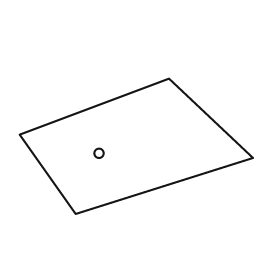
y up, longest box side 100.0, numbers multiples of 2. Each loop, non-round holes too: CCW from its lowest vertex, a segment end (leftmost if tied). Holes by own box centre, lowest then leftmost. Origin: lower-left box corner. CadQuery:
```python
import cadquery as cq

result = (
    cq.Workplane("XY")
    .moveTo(24.0, 0.0)
    .lineTo(100.0, 24.0)
    .lineTo(64.0, 58.0)
    .lineTo(0.0, 34.0)
    .close()
    .moveTo(34.0, 26.0)
    .circle(2.0)
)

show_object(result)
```